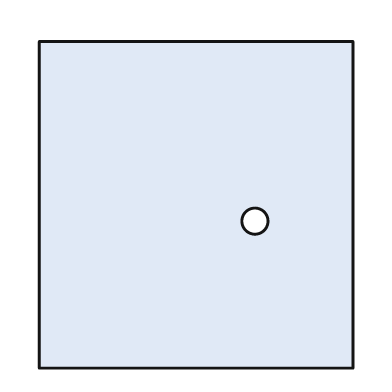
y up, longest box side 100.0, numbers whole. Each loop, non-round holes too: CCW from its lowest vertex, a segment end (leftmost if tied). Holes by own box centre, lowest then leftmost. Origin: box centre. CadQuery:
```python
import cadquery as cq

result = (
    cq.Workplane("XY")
    .moveTo(-48.0, -50.0)
    .lineTo(48.0, -50.0)
    .lineTo(48.0, 50.0)
    .lineTo(-48.0, 50.0)
    .close()
    .moveTo(18.0, -5.0)
    .circle(4.0)
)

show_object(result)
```